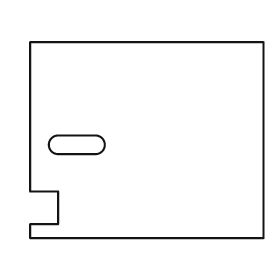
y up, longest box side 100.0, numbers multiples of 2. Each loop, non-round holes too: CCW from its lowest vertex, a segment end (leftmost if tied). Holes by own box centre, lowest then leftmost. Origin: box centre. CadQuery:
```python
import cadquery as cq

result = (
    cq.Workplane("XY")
    .moveTo(-50.0, -42.0)
    .lineTo(50.0, -42.0)
    .lineTo(50.0, 42.0)
    .lineTo(-50.0, 42.0)
    .lineTo(-50.0, -22.0)
    .lineTo(-38.0, -22.0)
    .lineTo(-38.0, -36.0)
    .lineTo(-50.0, -36.0)
    .close()
    .moveTo(-38.0, -6.0)
    .lineTo(-22.0, -6.0)
    .threePointArc((-18.0, -2.0), (-22.0, 2.0))
    .lineTo(-38.0, 2.0)
    .threePointArc((-42.0, -2.0), (-38.0, -6.0))
    .close()
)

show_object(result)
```